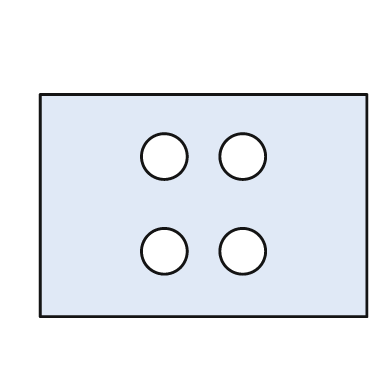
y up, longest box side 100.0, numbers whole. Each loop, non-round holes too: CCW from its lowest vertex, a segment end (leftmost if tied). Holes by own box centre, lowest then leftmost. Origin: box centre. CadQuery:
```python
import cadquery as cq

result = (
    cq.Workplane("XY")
    .moveTo(-50.0, -34.0)
    .lineTo(50.0, -34.0)
    .lineTo(50.0, 34.0)
    .lineTo(-50.0, 34.0)
    .close()
    .moveTo(-12.0, -14.0)
    .circle(7.0)
    .moveTo(12.0, -14.0)
    .circle(7.0)
    .moveTo(-12.0, 15.0)
    .circle(7.0)
    .moveTo(12.0, 15.0)
    .circle(7.0)
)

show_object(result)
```